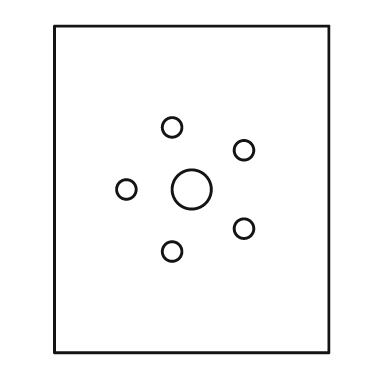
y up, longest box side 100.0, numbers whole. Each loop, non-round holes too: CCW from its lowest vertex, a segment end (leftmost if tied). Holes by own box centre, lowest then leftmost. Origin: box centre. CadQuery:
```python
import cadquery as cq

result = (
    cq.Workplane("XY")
    .moveTo(-42.0, -50.0)
    .lineTo(42.0, -50.0)
    .lineTo(42.0, 50.0)
    .lineTo(-42.0, 50.0)
    .close()
    .moveTo(-6.0, -19.0)
    .circle(3.0)
    .moveTo(16.0, -12.0)
    .circle(3.0)
    .moveTo(-20.0, 0.0)
    .circle(3.0)
    .moveTo(0.0, 0.0)
    .circle(6.0)
    .moveTo(16.0, 12.0)
    .circle(3.0)
    .moveTo(-6.0, 19.0)
    .circle(3.0)
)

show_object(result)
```